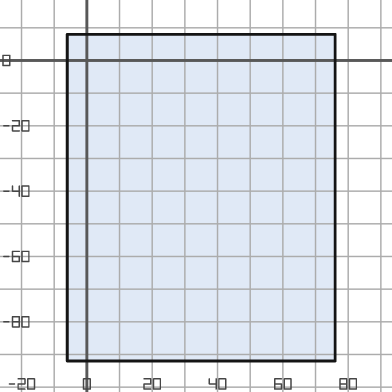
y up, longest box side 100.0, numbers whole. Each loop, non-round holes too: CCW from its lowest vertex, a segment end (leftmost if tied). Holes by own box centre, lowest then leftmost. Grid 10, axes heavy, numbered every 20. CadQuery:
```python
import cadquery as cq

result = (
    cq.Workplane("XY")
    .moveTo(-6.0, -92.0)
    .lineTo(76.0, -92.0)
    .lineTo(76.0, 8.0)
    .lineTo(-6.0, 8.0)
    .close()
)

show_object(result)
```